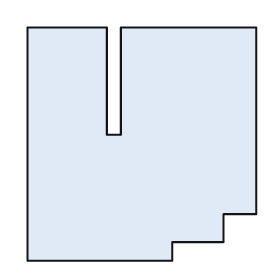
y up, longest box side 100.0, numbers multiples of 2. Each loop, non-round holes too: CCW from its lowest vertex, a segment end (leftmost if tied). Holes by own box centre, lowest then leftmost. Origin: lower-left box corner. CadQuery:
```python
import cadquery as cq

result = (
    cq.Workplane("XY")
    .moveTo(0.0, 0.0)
    .lineTo(62.0, 0.0)
    .lineTo(62.0, 8.0)
    .lineTo(84.0, 8.0)
    .lineTo(84.0, 20.0)
    .lineTo(98.0, 20.0)
    .lineTo(98.0, 100.0)
    .lineTo(40.0, 100.0)
    .lineTo(40.0, 54.0)
    .lineTo(34.0, 54.0)
    .lineTo(34.0, 100.0)
    .lineTo(0.0, 100.0)
    .close()
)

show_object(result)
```